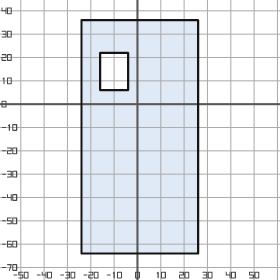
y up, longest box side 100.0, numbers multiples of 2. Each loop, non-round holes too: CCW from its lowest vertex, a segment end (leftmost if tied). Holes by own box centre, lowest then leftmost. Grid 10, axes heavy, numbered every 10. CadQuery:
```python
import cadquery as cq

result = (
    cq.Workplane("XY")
    .moveTo(-24.0, -64.0)
    .lineTo(26.0, -64.0)
    .lineTo(26.0, 36.0)
    .lineTo(-24.0, 36.0)
    .close()
    .moveTo(-16.0, 6.0)
    .lineTo(-4.0, 6.0)
    .lineTo(-4.0, 22.0)
    .lineTo(-16.0, 22.0)
    .close()
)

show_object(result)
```